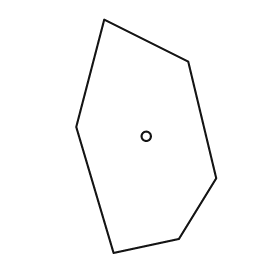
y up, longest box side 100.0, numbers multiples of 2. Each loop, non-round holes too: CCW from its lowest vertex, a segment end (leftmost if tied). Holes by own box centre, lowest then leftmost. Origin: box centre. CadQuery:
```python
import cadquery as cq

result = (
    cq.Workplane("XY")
    .moveTo(-14.0, -50.0)
    .lineTo(14.0, -44.0)
    .lineTo(30.0, -18.0)
    .lineTo(18.0, 32.0)
    .lineTo(-18.0, 50.0)
    .lineTo(-30.0, 4.0)
    .close()
    .moveTo(0.0, 0.0)
    .circle(2.0)
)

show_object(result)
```